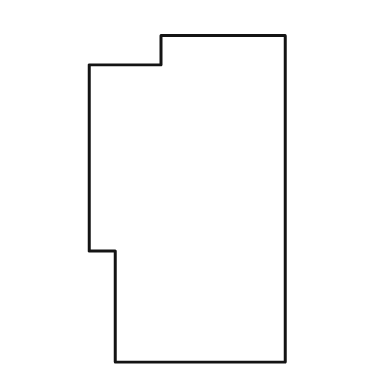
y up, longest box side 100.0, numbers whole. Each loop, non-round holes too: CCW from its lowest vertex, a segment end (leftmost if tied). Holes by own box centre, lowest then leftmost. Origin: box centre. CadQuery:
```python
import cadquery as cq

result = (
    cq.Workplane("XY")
    .moveTo(-22.0, -50.0)
    .lineTo(30.0, -50.0)
    .lineTo(30.0, 50.0)
    .lineTo(-8.0, 50.0)
    .lineTo(-8.0, 41.0)
    .lineTo(-30.0, 41.0)
    .lineTo(-30.0, -16.0)
    .lineTo(-22.0, -16.0)
    .close()
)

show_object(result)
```